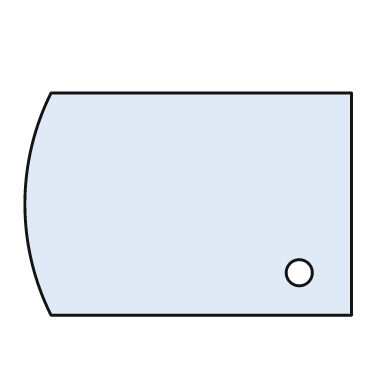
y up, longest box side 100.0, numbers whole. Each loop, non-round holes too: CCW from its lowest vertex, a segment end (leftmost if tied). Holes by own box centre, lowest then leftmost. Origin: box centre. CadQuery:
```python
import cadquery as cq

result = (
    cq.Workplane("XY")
    .moveTo(-42.0, -34.0)
    .lineTo(50.0, -34.0)
    .lineTo(50.0, 34.0)
    .lineTo(-42.0, 34.0)
    .threePointArc((-50.0, 0.0), (-42.0, -34.0))
    .close()
    .moveTo(34.0, -21.0)
    .circle(4.0)
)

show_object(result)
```